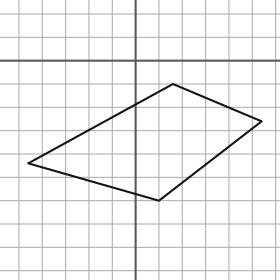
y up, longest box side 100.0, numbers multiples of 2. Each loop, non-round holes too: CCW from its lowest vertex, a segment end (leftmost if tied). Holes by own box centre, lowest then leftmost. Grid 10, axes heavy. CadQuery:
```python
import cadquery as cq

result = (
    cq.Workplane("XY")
    .moveTo(10.0, -60.0)
    .lineTo(54.0, -26.0)
    .lineTo(16.0, -10.0)
    .lineTo(-46.0, -44.0)
    .close()
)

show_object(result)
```